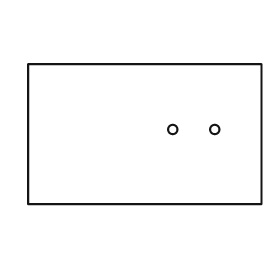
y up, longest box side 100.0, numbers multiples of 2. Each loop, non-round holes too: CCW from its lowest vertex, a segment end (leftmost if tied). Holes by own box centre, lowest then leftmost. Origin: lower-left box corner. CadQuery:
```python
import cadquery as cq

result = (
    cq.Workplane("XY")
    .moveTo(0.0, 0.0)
    .lineTo(100.0, 0.0)
    .lineTo(100.0, 60.0)
    .lineTo(0.0, 60.0)
    .close()
    .moveTo(62.0, 32.0)
    .circle(2.0)
    .moveTo(80.0, 32.0)
    .circle(2.0)
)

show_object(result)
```